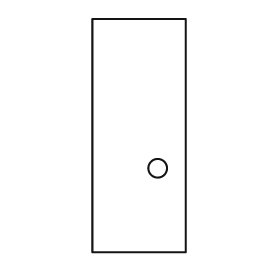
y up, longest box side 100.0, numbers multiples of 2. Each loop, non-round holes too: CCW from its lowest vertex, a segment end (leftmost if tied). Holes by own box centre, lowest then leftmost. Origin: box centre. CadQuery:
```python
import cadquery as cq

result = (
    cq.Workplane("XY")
    .moveTo(-20.0, -50.0)
    .lineTo(20.0, -50.0)
    .lineTo(20.0, 50.0)
    .lineTo(-20.0, 50.0)
    .close()
    .moveTo(8.0, -14.0)
    .circle(4.0)
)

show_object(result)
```